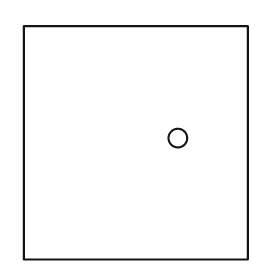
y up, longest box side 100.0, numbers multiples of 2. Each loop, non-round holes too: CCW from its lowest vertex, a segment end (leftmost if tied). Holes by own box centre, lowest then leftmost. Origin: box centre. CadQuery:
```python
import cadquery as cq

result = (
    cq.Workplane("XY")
    .moveTo(-48.0, -50.0)
    .lineTo(48.0, -50.0)
    .lineTo(48.0, 50.0)
    .lineTo(-48.0, 50.0)
    .close()
    .moveTo(18.0, 2.0)
    .circle(4.0)
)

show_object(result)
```